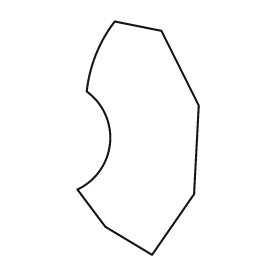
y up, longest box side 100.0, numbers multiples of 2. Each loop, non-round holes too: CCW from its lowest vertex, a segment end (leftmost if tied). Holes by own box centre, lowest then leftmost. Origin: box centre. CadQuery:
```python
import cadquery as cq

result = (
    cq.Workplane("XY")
    .moveTo(6.0, -50.0)
    .lineTo(24.0, -24.0)
    .lineTo(26.0, 14.0)
    .lineTo(10.0, 46.0)
    .lineTo(-10.0, 50.0)
    .threePointArc((-18.0, 36.0), (-22.0, 20.0))
    .threePointArc((-12.0, -2.0), (-26.0, -22.0))
    .lineTo(-14.0, -38.0)
    .close()
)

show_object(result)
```